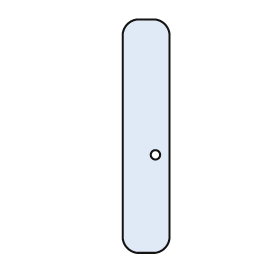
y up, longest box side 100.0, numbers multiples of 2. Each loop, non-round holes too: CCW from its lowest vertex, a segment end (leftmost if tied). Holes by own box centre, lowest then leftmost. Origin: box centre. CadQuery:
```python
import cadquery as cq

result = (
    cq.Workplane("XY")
    .moveTo(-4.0, -50.0)
    .lineTo(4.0, -50.0)
    .threePointArc((8.0, -48.0), (10.0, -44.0))
    .lineTo(10.0, 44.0)
    .threePointArc((8.0, 48.0), (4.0, 50.0))
    .lineTo(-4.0, 50.0)
    .threePointArc((-8.0, 48.0), (-10.0, 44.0))
    .lineTo(-10.0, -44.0)
    .threePointArc((-8.0, -48.0), (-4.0, -50.0))
    .close()
    .moveTo(4.0, -8.0)
    .circle(2.0)
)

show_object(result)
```